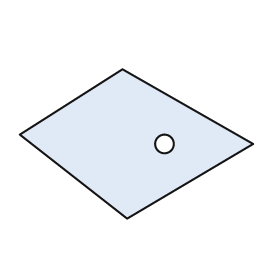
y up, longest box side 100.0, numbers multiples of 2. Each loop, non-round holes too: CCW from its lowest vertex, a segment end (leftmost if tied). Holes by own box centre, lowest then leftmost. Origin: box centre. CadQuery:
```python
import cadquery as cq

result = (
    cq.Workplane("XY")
    .moveTo(-4.0, -32.0)
    .lineTo(50.0, 0.0)
    .lineTo(-6.0, 32.0)
    .lineTo(-50.0, 4.0)
    .close()
    .moveTo(12.0, 0.0)
    .circle(4.0)
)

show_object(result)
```